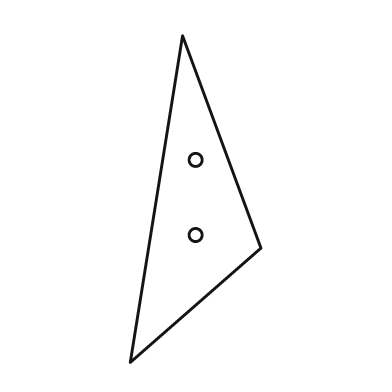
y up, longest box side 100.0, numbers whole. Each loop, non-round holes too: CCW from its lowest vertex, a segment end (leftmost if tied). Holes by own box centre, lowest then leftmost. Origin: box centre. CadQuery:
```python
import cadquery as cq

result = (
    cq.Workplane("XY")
    .moveTo(-20.0, -50.0)
    .lineTo(20.0, -15.0)
    .lineTo(-4.0, 50.0)
    .close()
    .moveTo(0.0, -11.0)
    .circle(2.0)
    .moveTo(0.0, 12.0)
    .circle(2.0)
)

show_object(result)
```